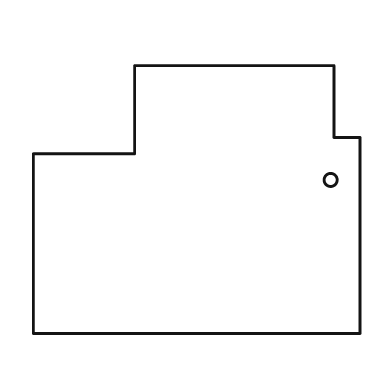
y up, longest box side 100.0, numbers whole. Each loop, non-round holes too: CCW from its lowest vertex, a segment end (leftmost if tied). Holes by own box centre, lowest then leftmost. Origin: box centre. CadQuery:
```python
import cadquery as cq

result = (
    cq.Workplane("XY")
    .moveTo(-50.0, -41.0)
    .lineTo(50.0, -41.0)
    .lineTo(50.0, 19.0)
    .lineTo(42.0, 19.0)
    .lineTo(42.0, 41.0)
    .lineTo(-19.0, 41.0)
    .lineTo(-19.0, 14.0)
    .lineTo(-50.0, 14.0)
    .close()
    .moveTo(41.0, 6.0)
    .circle(2.0)
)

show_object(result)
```